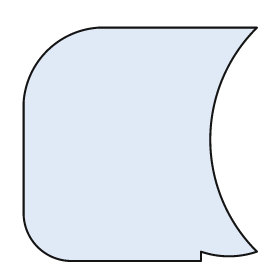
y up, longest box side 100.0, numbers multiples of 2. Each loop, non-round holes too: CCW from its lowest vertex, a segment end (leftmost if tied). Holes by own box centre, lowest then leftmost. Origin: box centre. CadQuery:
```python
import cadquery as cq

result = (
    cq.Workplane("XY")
    .moveTo(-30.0, -50.0)
    .lineTo(26.0, -50.0)
    .lineTo(26.0, -46.0)
    .threePointArc((38.0, -48.0), (50.0, -46.0))
    .threePointArc((30.0, 2.0), (50.0, 50.0))
    .lineTo(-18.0, 50.0)
    .threePointArc((-40.0, 40.0), (-50.0, 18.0))
    .lineTo(-50.0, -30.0)
    .threePointArc((-44.0, -44.0), (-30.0, -50.0))
    .close()
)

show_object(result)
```